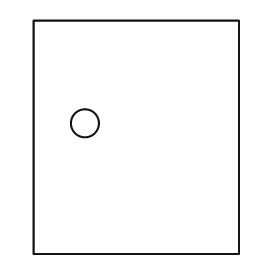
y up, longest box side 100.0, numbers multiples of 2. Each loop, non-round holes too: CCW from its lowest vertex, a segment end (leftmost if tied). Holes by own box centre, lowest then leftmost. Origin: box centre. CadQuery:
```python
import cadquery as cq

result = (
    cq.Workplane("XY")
    .moveTo(-44.0, -50.0)
    .lineTo(44.0, -50.0)
    .lineTo(44.0, 50.0)
    .lineTo(-44.0, 50.0)
    .close()
    .moveTo(-22.0, 6.0)
    .circle(6.0)
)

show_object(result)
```